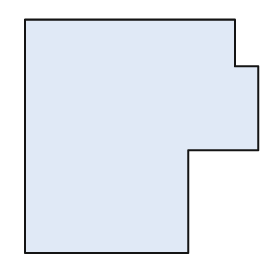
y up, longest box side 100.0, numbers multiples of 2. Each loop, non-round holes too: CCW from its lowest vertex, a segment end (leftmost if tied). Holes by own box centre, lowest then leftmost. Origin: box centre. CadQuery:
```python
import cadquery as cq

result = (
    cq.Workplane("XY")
    .moveTo(-50.0, -50.0)
    .lineTo(20.0, -50.0)
    .lineTo(20.0, -6.0)
    .lineTo(50.0, -6.0)
    .lineTo(50.0, 30.0)
    .lineTo(40.0, 30.0)
    .lineTo(40.0, 50.0)
    .lineTo(-50.0, 50.0)
    .close()
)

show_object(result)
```